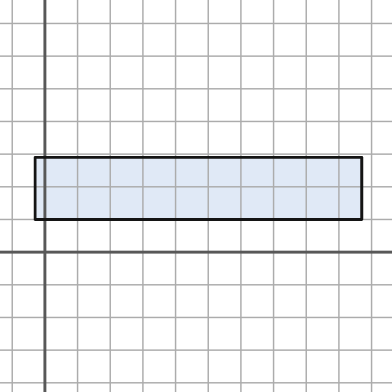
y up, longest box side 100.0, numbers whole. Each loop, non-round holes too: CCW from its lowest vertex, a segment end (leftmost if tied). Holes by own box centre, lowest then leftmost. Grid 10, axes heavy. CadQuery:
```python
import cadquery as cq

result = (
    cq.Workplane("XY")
    .moveTo(-3.0, 10.0)
    .lineTo(97.0, 10.0)
    .lineTo(97.0, 29.0)
    .lineTo(-3.0, 29.0)
    .close()
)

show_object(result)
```